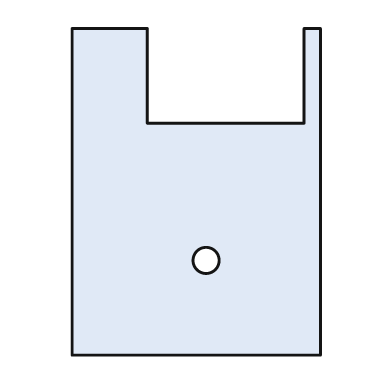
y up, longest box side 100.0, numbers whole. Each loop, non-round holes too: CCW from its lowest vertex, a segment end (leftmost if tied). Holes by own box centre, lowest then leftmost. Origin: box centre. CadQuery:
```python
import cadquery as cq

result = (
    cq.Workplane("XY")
    .moveTo(-38.0, -50.0)
    .lineTo(38.0, -50.0)
    .lineTo(38.0, 50.0)
    .lineTo(33.0, 50.0)
    .lineTo(33.0, 21.0)
    .lineTo(-15.0, 21.0)
    .lineTo(-15.0, 50.0)
    .lineTo(-38.0, 50.0)
    .close()
    .moveTo(3.0, -21.0)
    .circle(4.0)
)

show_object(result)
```